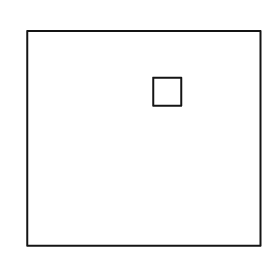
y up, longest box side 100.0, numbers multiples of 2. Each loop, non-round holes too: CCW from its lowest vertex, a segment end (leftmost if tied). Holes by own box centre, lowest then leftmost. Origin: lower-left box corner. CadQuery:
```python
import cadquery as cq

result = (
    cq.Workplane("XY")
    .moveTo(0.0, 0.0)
    .lineTo(100.0, 0.0)
    .lineTo(100.0, 92.0)
    .lineTo(0.0, 92.0)
    .close()
    .moveTo(54.0, 60.0)
    .lineTo(66.0, 60.0)
    .lineTo(66.0, 72.0)
    .lineTo(54.0, 72.0)
    .close()
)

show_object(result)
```